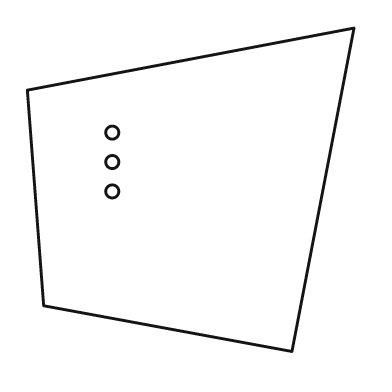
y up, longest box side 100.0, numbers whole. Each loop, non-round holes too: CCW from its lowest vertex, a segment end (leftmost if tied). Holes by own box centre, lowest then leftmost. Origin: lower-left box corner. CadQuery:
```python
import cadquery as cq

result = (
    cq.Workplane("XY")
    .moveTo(81.0, 0.0)
    .lineTo(100.0, 99.0)
    .lineTo(0.0, 80.0)
    .lineTo(5.0, 14.0)
    .close()
    .moveTo(26.0, 49.0)
    .circle(2.0)
    .moveTo(26.0, 58.0)
    .circle(2.0)
    .moveTo(26.0, 67.0)
    .circle(2.0)
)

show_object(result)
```